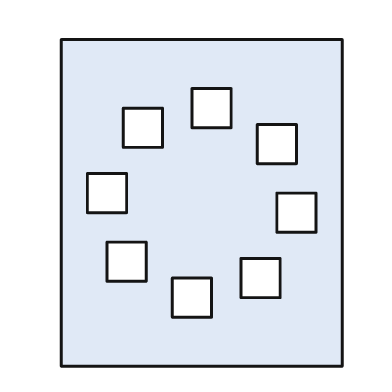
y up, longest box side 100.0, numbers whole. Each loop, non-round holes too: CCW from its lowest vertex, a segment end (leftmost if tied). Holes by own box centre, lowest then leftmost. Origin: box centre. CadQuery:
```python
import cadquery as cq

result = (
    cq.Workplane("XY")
    .moveTo(-43.0, -50.0)
    .lineTo(43.0, -50.0)
    .lineTo(43.0, 50.0)
    .lineTo(-43.0, 50.0)
    .close()
    .moveTo(-9.0, -35.0)
    .lineTo(3.0, -35.0)
    .lineTo(3.0, -23.0)
    .lineTo(-9.0, -23.0)
    .close()
    .moveTo(12.0, -29.0)
    .lineTo(24.0, -29.0)
    .lineTo(24.0, -17.0)
    .lineTo(12.0, -17.0)
    .close()
    .moveTo(-29.0, -24.0)
    .lineTo(-17.0, -24.0)
    .lineTo(-17.0, -12.0)
    .lineTo(-29.0, -12.0)
    .close()
    .moveTo(23.0, -9.0)
    .lineTo(35.0, -9.0)
    .lineTo(35.0, 3.0)
    .lineTo(23.0, 3.0)
    .close()
    .moveTo(-35.0, -3.0)
    .lineTo(-23.0, -3.0)
    .lineTo(-23.0, 9.0)
    .lineTo(-35.0, 9.0)
    .close()
    .moveTo(17.0, 12.0)
    .lineTo(29.0, 12.0)
    .lineTo(29.0, 24.0)
    .lineTo(17.0, 24.0)
    .close()
    .moveTo(-24.0, 17.0)
    .lineTo(-12.0, 17.0)
    .lineTo(-12.0, 29.0)
    .lineTo(-24.0, 29.0)
    .close()
    .moveTo(-3.0, 23.0)
    .lineTo(9.0, 23.0)
    .lineTo(9.0, 35.0)
    .lineTo(-3.0, 35.0)
    .close()
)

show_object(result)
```